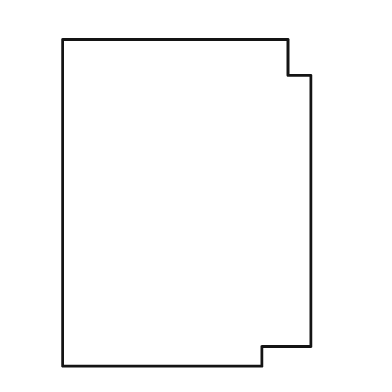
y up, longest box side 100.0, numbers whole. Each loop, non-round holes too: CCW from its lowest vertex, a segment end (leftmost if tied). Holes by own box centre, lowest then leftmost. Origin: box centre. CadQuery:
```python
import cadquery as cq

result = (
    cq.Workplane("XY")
    .moveTo(-38.0, -50.0)
    .lineTo(23.0, -50.0)
    .lineTo(23.0, -44.0)
    .lineTo(38.0, -44.0)
    .lineTo(38.0, 39.0)
    .lineTo(31.0, 39.0)
    .lineTo(31.0, 50.0)
    .lineTo(-38.0, 50.0)
    .close()
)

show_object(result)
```